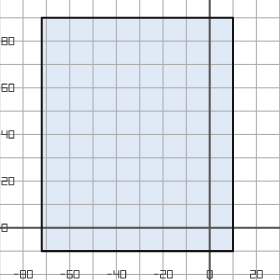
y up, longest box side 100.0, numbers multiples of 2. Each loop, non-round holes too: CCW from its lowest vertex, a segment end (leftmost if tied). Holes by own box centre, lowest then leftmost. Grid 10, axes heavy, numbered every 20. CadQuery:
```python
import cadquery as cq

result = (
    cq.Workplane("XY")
    .moveTo(-72.0, -10.0)
    .lineTo(10.0, -10.0)
    .lineTo(10.0, 90.0)
    .lineTo(-72.0, 90.0)
    .close()
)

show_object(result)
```